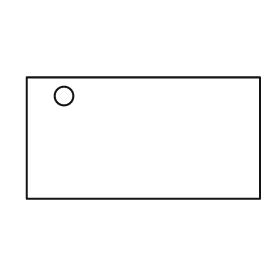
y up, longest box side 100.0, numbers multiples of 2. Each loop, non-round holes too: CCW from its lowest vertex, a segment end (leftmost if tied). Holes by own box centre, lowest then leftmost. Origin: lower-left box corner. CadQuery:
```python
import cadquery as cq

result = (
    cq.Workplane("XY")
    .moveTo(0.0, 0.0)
    .lineTo(100.0, 0.0)
    .lineTo(100.0, 52.0)
    .lineTo(0.0, 52.0)
    .close()
    .moveTo(16.0, 44.0)
    .circle(4.0)
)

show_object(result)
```